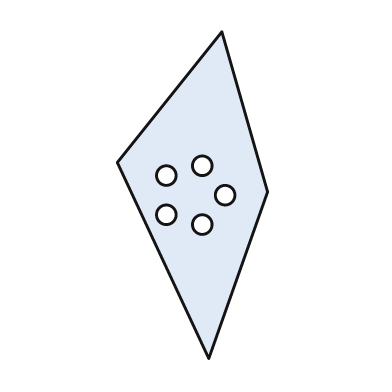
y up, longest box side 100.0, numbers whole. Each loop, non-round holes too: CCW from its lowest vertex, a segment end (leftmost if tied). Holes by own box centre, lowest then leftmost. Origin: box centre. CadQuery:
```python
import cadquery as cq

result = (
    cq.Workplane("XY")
    .moveTo(5.0, -50.0)
    .lineTo(23.0, 1.0)
    .lineTo(9.0, 50.0)
    .lineTo(-23.0, 10.0)
    .close()
    .moveTo(3.0, -9.0)
    .circle(3.0)
    .moveTo(-8.0, -6.0)
    .circle(3.0)
    .moveTo(10.0, 0.0)
    .circle(3.0)
    .moveTo(-8.0, 6.0)
    .circle(3.0)
    .moveTo(3.0, 9.0)
    .circle(3.0)
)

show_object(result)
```